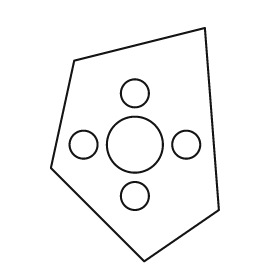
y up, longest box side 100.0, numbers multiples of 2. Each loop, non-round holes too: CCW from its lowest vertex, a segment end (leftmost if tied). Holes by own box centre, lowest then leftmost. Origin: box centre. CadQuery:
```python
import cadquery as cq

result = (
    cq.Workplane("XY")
    .moveTo(4.0, -50.0)
    .lineTo(36.0, -28.0)
    .lineTo(30.0, 50.0)
    .lineTo(-26.0, 36.0)
    .lineTo(-36.0, -10.0)
    .close()
    .moveTo(0.0, -22.0)
    .circle(6.0)
    .moveTo(-22.0, 0.0)
    .circle(6.0)
    .moveTo(0.0, 0.0)
    .circle(12.0)
    .moveTo(22.0, 0.0)
    .circle(6.0)
    .moveTo(0.0, 22.0)
    .circle(6.0)
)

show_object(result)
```